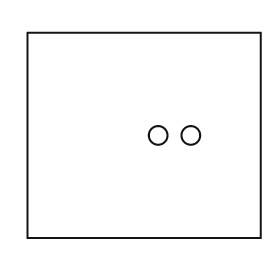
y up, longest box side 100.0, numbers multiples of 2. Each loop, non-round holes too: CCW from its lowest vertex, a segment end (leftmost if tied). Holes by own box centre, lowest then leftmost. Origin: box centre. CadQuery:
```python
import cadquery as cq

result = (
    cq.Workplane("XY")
    .moveTo(-50.0, -44.0)
    .lineTo(50.0, -44.0)
    .lineTo(50.0, 44.0)
    .lineTo(-50.0, 44.0)
    .close()
    .moveTo(6.0, 0.0)
    .circle(4.0)
    .moveTo(20.0, 0.0)
    .circle(4.0)
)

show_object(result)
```